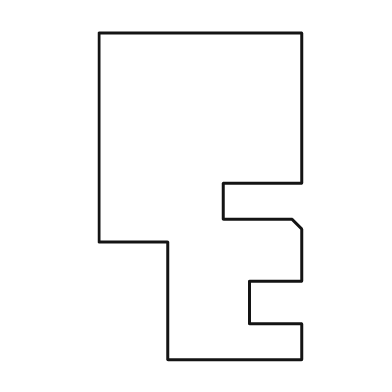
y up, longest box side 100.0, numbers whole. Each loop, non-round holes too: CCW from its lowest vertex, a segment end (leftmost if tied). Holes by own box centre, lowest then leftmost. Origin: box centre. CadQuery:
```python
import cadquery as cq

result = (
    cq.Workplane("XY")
    .moveTo(-10.0, -50.0)
    .lineTo(31.0, -50.0)
    .lineTo(31.0, -39.0)
    .lineTo(15.0, -39.0)
    .lineTo(15.0, -26.0)
    .lineTo(31.0, -26.0)
    .lineTo(31.0, -10.0)
    .lineTo(28.0, -7.0)
    .lineTo(7.0, -7.0)
    .lineTo(7.0, 4.0)
    .lineTo(31.0, 4.0)
    .lineTo(31.0, 50.0)
    .lineTo(-31.0, 50.0)
    .lineTo(-31.0, -14.0)
    .lineTo(-10.0, -14.0)
    .close()
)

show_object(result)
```